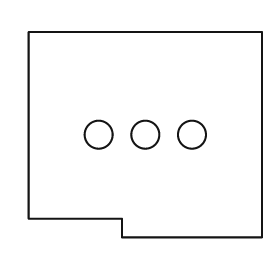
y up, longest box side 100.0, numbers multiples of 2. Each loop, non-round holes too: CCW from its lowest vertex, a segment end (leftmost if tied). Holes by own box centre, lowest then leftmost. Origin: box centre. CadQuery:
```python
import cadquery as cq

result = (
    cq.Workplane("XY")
    .moveTo(-10.0, -44.0)
    .lineTo(50.0, -44.0)
    .lineTo(50.0, 44.0)
    .lineTo(-50.0, 44.0)
    .lineTo(-50.0, -36.0)
    .lineTo(-10.0, -36.0)
    .close()
    .moveTo(-20.0, 0.0)
    .circle(6.0)
    .moveTo(0.0, 0.0)
    .circle(6.0)
    .moveTo(20.0, 0.0)
    .circle(6.0)
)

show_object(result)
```